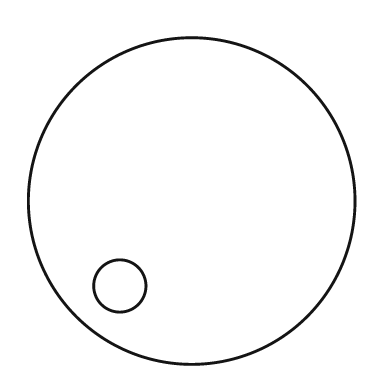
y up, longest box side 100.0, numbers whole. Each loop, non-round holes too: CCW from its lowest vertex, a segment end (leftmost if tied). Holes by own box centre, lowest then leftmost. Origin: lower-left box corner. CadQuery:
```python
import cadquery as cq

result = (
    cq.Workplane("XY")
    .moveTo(50.0, 50.0)
    .circle(50.0)
    .moveTo(28.0, 24.0)
    .circle(8.0)
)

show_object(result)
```